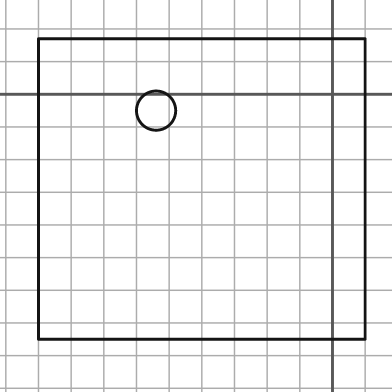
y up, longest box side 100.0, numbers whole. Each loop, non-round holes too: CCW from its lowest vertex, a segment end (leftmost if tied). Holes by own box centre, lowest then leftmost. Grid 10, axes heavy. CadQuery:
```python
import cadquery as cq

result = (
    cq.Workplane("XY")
    .moveTo(-90.0, -75.0)
    .lineTo(10.0, -75.0)
    .lineTo(10.0, 17.0)
    .lineTo(-90.0, 17.0)
    .close()
    .moveTo(-54.0, -5.0)
    .circle(6.0)
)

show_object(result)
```